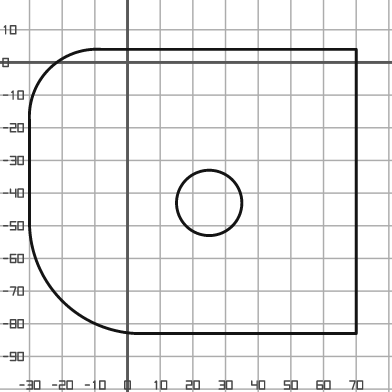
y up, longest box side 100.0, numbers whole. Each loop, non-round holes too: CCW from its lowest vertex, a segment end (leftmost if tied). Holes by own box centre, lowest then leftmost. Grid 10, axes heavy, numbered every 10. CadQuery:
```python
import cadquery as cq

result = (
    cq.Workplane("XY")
    .moveTo(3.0, -83.0)
    .lineTo(70.0, -83.0)
    .lineTo(70.0, 4.0)
    .lineTo(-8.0, 4.0)
    .threePointArc((-24.0, -2.0), (-30.0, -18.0))
    .lineTo(-30.0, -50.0)
    .threePointArc((-20.0, -73.0), (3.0, -83.0))
    .close()
    .moveTo(25.0, -43.0)
    .circle(10.0)
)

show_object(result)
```